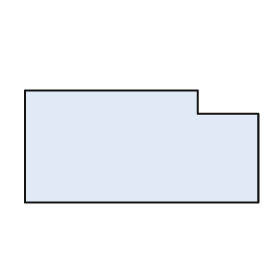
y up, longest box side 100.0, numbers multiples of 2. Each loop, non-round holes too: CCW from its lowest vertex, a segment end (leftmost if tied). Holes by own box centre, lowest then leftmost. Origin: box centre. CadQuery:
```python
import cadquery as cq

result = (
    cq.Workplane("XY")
    .moveTo(-50.0, -24.0)
    .lineTo(50.0, -24.0)
    .lineTo(50.0, 14.0)
    .lineTo(24.0, 14.0)
    .lineTo(24.0, 24.0)
    .lineTo(-50.0, 24.0)
    .close()
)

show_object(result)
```